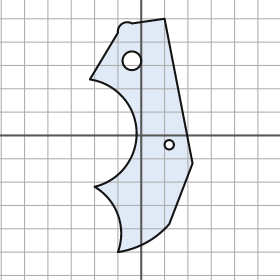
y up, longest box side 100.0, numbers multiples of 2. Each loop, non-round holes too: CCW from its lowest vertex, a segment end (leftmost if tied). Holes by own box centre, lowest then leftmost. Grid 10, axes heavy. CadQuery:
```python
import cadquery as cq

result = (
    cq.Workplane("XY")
    .moveTo(-10.0, -50.0)
    .threePointArc((2.0, -46.0), (12.0, -38.0))
    .lineTo(22.0, -12.0)
    .lineTo(10.0, 50.0)
    .lineTo(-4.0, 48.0)
    .threePointArc((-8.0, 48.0), (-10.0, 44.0))
    .lineTo(-22.0, 24.0)
    .threePointArc((-2.0, 2.0), (-20.0, -22.0))
    .threePointArc((-10.0, -34.0), (-10.0, -50.0))
    .close()
    .moveTo(12.0, -4.0)
    .circle(2.0)
    .moveTo(-4.0, 32.0)
    .circle(4.0)
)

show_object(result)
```